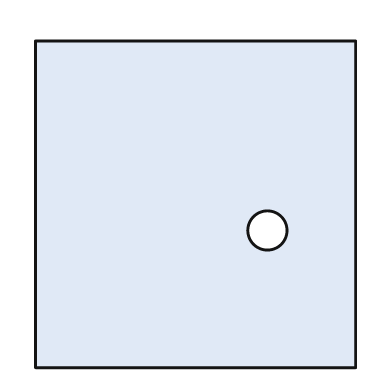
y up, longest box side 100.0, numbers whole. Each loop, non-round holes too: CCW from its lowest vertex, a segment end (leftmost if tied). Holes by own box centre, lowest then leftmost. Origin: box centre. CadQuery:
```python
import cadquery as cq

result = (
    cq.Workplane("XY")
    .moveTo(-49.0, -50.0)
    .lineTo(49.0, -50.0)
    .lineTo(49.0, 50.0)
    .lineTo(-49.0, 50.0)
    .close()
    .moveTo(22.0, -8.0)
    .circle(6.0)
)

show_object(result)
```